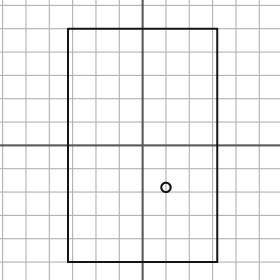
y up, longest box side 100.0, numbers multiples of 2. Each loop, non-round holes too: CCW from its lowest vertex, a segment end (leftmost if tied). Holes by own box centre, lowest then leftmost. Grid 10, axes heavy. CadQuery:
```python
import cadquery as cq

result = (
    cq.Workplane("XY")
    .moveTo(-32.0, -50.0)
    .lineTo(32.0, -50.0)
    .lineTo(32.0, 50.0)
    .lineTo(-32.0, 50.0)
    .close()
    .moveTo(10.0, -18.0)
    .circle(2.0)
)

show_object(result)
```